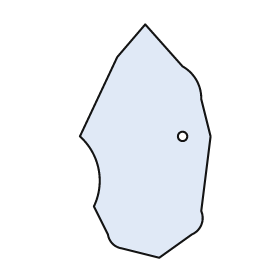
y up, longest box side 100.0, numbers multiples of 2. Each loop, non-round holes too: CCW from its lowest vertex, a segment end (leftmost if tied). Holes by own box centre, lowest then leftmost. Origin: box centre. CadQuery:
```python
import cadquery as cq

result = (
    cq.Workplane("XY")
    .moveTo(6.0, -50.0)
    .lineTo(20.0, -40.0)
    .threePointArc((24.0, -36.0), (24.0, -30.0))
    .lineTo(28.0, 2.0)
    .lineTo(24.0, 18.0)
    .threePointArc((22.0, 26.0), (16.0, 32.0))
    .lineTo(0.0, 50.0)
    .lineTo(-12.0, 36.0)
    .lineTo(-28.0, 2.0)
    .threePointArc((-20.0, -12.0), (-22.0, -28.0))
    .lineTo(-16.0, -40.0)
    .threePointArc((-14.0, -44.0), (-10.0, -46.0))
    .close()
    .moveTo(16.0, 2.0)
    .circle(2.0)
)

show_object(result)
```